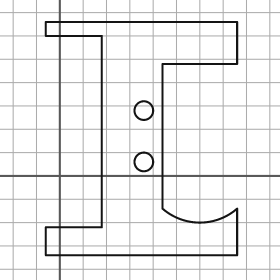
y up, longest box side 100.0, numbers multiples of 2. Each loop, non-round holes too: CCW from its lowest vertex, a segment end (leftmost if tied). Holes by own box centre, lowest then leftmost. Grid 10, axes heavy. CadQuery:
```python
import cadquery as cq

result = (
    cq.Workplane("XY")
    .moveTo(-6.0, -34.0)
    .lineTo(76.0, -34.0)
    .lineTo(76.0, -14.0)
    .threePointArc((60.0, -20.0), (44.0, -14.0))
    .lineTo(44.0, 48.0)
    .lineTo(76.0, 48.0)
    .lineTo(76.0, 66.0)
    .lineTo(-6.0, 66.0)
    .lineTo(-6.0, 60.0)
    .lineTo(18.0, 60.0)
    .lineTo(18.0, -22.0)
    .lineTo(-6.0, -22.0)
    .close()
    .moveTo(36.0, 6.0)
    .circle(4.0)
    .moveTo(36.0, 28.0)
    .circle(4.0)
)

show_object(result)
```